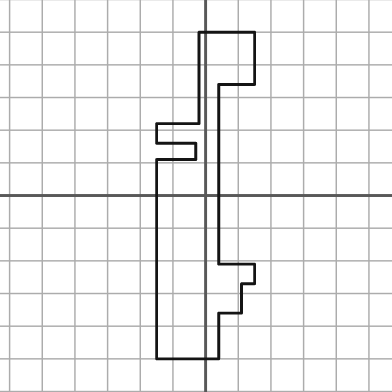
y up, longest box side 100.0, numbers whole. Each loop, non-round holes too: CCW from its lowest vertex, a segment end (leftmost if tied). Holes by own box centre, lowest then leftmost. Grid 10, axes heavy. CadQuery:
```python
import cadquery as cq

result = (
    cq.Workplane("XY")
    .moveTo(-15.0, -50.0)
    .lineTo(4.0, -50.0)
    .lineTo(4.0, -36.0)
    .lineTo(11.0, -36.0)
    .lineTo(11.0, -27.0)
    .lineTo(15.0, -27.0)
    .lineTo(15.0, -21.0)
    .lineTo(4.0, -21.0)
    .lineTo(4.0, 34.0)
    .lineTo(15.0, 34.0)
    .lineTo(15.0, 50.0)
    .lineTo(-2.0, 50.0)
    .lineTo(-2.0, 22.0)
    .lineTo(-15.0, 22.0)
    .lineTo(-15.0, 16.0)
    .lineTo(-3.0, 16.0)
    .lineTo(-3.0, 11.0)
    .lineTo(-15.0, 11.0)
    .close()
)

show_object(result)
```